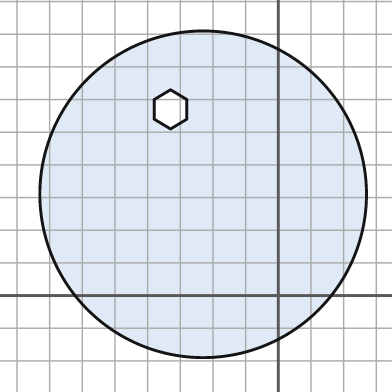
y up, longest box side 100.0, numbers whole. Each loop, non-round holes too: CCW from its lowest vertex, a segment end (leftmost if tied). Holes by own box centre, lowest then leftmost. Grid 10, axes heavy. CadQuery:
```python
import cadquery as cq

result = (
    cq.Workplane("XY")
    .moveTo(-23.0, 31.0)
    .circle(50.0)
    .moveTo(-33.0, 51.0)
    .lineTo(-28.0, 54.0)
    .lineTo(-28.0, 60.0)
    .lineTo(-33.0, 63.0)
    .lineTo(-38.0, 60.0)
    .lineTo(-38.0, 54.0)
    .close()
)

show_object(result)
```